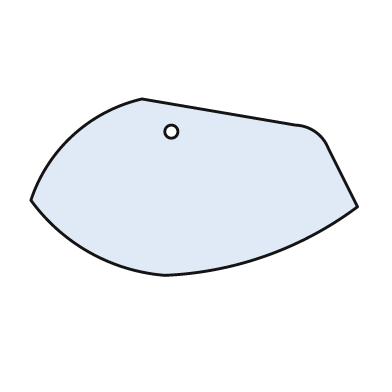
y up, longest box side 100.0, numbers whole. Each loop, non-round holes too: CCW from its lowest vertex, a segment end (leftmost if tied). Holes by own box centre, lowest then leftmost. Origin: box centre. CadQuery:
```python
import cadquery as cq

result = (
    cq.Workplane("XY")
    .moveTo(-9.0, -27.0)
    .threePointArc((22.0, -21.0), (50.0, -6.0))
    .lineTo(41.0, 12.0)
    .threePointArc((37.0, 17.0), (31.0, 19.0))
    .lineTo(-16.0, 27.0)
    .threePointArc((-37.0, 16.0), (-50.0, -4.0))
    .threePointArc((-32.0, -20.0), (-9.0, -27.0))
    .close()
    .moveTo(-7.0, 17.0)
    .circle(2.0)
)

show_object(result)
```